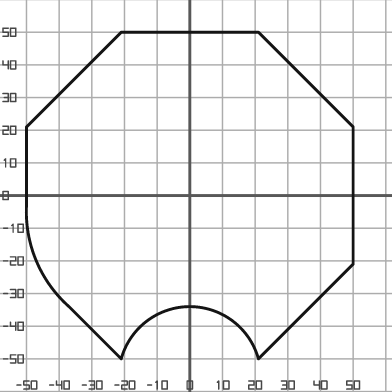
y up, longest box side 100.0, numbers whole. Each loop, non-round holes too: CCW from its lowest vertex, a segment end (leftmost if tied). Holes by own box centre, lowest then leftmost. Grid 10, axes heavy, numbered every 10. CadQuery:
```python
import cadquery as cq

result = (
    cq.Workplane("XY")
    .moveTo(-21.0, -50.0)
    .threePointArc((0.0, -34.0), (21.0, -50.0))
    .lineTo(50.0, -21.0)
    .lineTo(50.0, 21.0)
    .lineTo(21.0, 50.0)
    .lineTo(-21.0, 50.0)
    .lineTo(-50.0, 21.0)
    .lineTo(-50.0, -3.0)
    .threePointArc((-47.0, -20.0), (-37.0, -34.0))
    .close()
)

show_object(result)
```